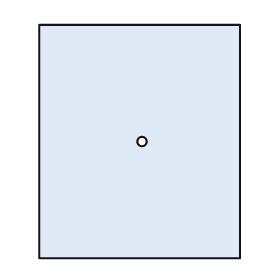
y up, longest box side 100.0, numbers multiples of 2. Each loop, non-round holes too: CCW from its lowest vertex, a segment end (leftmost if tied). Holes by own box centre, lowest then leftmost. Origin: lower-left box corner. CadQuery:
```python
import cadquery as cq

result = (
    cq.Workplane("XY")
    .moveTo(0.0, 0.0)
    .lineTo(86.0, 0.0)
    .lineTo(86.0, 100.0)
    .lineTo(0.0, 100.0)
    .close()
    .moveTo(44.0, 50.0)
    .circle(2.0)
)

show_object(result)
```